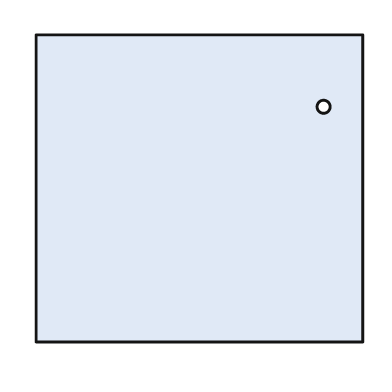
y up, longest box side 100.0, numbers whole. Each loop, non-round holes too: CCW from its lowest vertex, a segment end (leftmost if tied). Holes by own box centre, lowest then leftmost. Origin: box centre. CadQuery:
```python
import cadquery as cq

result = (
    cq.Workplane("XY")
    .moveTo(-50.0, -47.0)
    .lineTo(50.0, -47.0)
    .lineTo(50.0, 47.0)
    .lineTo(-50.0, 47.0)
    .close()
    .moveTo(38.0, 25.0)
    .circle(2.0)
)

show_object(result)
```